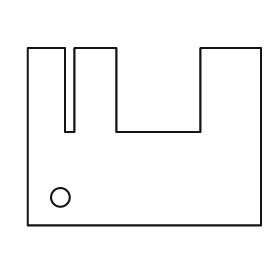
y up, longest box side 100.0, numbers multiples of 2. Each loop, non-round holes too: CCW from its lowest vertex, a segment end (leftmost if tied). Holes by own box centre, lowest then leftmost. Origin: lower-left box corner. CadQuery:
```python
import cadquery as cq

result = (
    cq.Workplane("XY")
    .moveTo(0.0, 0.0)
    .lineTo(100.0, 0.0)
    .lineTo(100.0, 76.0)
    .lineTo(74.0, 76.0)
    .lineTo(74.0, 40.0)
    .lineTo(38.0, 40.0)
    .lineTo(38.0, 76.0)
    .lineTo(20.0, 76.0)
    .lineTo(20.0, 40.0)
    .lineTo(16.0, 40.0)
    .lineTo(16.0, 76.0)
    .lineTo(0.0, 76.0)
    .close()
    .moveTo(14.0, 12.0)
    .circle(4.0)
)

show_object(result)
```